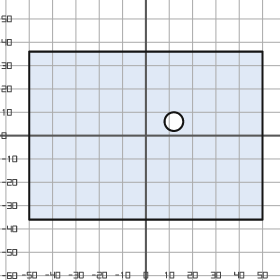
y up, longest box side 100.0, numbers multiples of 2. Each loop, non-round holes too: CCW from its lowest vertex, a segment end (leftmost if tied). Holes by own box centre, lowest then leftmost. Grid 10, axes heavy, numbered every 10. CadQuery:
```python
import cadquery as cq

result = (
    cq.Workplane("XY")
    .moveTo(-50.0, -36.0)
    .lineTo(50.0, -36.0)
    .lineTo(50.0, 36.0)
    .lineTo(-50.0, 36.0)
    .close()
    .moveTo(12.0, 6.0)
    .circle(4.0)
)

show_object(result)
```